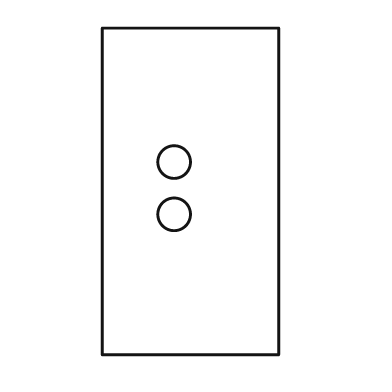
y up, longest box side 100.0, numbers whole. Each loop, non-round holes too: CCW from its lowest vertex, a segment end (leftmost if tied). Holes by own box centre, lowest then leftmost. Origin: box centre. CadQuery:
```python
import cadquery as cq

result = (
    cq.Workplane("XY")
    .moveTo(-27.0, -50.0)
    .lineTo(27.0, -50.0)
    .lineTo(27.0, 50.0)
    .lineTo(-27.0, 50.0)
    .close()
    .moveTo(-5.0, -7.0)
    .circle(5.0)
    .moveTo(-5.0, 9.0)
    .circle(5.0)
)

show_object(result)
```